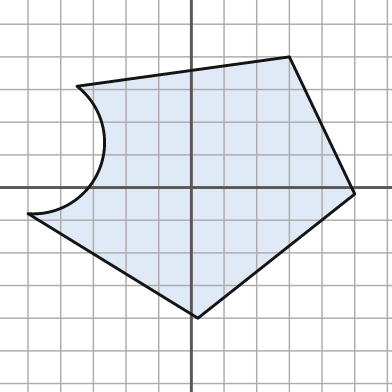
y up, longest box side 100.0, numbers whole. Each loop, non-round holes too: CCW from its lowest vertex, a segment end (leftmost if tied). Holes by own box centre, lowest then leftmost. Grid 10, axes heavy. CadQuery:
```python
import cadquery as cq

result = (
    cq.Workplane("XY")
    .moveTo(2.0, -40.0)
    .lineTo(50.0, -2.0)
    .lineTo(30.0, 40.0)
    .lineTo(-35.0, 31.0)
    .threePointArc((-28.0, 6.0), (-50.0, -8.0))
    .close()
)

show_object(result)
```